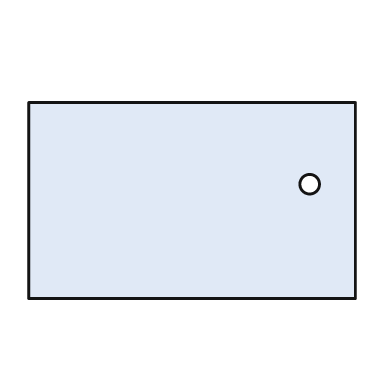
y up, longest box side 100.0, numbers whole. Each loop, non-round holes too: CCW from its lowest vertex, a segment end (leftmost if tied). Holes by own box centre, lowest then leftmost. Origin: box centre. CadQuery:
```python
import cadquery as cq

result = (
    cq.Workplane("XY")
    .moveTo(-50.0, -30.0)
    .lineTo(50.0, -30.0)
    .lineTo(50.0, 30.0)
    .lineTo(-50.0, 30.0)
    .close()
    .moveTo(36.0, 5.0)
    .circle(3.0)
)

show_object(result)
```